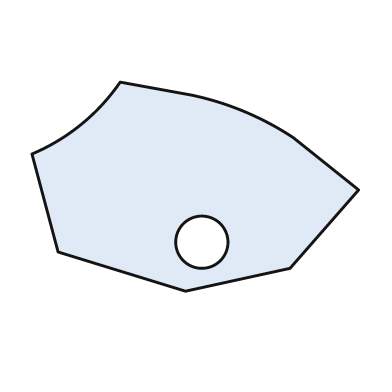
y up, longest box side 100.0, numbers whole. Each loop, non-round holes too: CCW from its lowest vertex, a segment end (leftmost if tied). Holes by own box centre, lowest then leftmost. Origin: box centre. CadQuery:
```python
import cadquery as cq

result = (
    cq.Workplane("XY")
    .moveTo(-3.0, -32.0)
    .lineTo(29.0, -25.0)
    .lineTo(50.0, -1.0)
    .lineTo(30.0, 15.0)
    .threePointArc((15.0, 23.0), (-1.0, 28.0))
    .lineTo(-23.0, 32.0)
    .threePointArc((-35.0, 19.0), (-50.0, 10.0))
    .lineTo(-42.0, -20.0)
    .close()
    .moveTo(2.0, -17.0)
    .circle(8.0)
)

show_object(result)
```